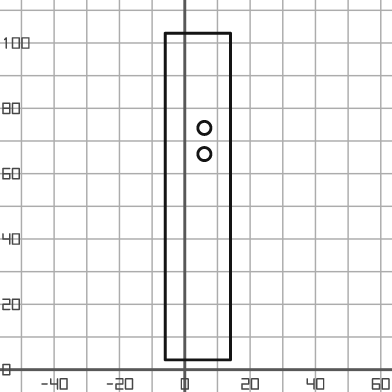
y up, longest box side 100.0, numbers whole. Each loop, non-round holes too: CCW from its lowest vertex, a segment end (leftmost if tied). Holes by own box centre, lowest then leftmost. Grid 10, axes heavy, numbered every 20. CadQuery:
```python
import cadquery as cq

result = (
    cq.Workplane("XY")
    .moveTo(-6.0, 3.0)
    .lineTo(14.0, 3.0)
    .lineTo(14.0, 103.0)
    .lineTo(-6.0, 103.0)
    .close()
    .moveTo(6.0, 66.0)
    .circle(2.0)
    .moveTo(6.0, 74.0)
    .circle(2.0)
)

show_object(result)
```